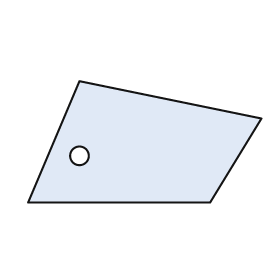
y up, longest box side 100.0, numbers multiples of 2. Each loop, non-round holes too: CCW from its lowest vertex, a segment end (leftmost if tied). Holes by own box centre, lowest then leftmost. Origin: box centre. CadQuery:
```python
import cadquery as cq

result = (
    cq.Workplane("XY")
    .moveTo(-50.0, -26.0)
    .lineTo(28.0, -26.0)
    .lineTo(50.0, 10.0)
    .lineTo(-28.0, 26.0)
    .close()
    .moveTo(-28.0, -6.0)
    .circle(4.0)
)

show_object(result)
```